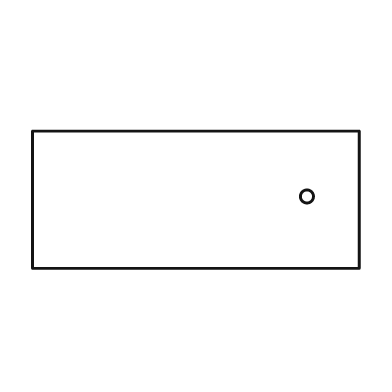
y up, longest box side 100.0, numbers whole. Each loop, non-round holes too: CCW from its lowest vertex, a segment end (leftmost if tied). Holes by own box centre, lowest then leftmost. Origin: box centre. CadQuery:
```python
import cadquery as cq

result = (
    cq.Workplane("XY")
    .moveTo(-50.0, -21.0)
    .lineTo(50.0, -21.0)
    .lineTo(50.0, 21.0)
    .lineTo(-50.0, 21.0)
    .close()
    .moveTo(34.0, 1.0)
    .circle(2.0)
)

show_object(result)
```